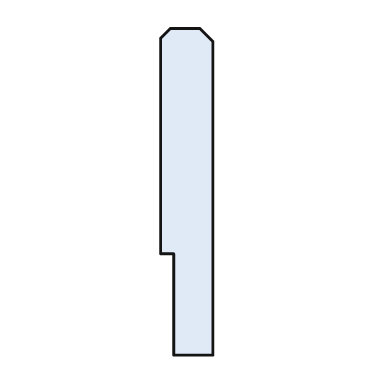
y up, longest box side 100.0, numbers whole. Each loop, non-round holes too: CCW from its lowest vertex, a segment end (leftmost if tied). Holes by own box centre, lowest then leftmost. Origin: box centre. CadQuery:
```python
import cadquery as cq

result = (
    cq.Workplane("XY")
    .moveTo(-4.0, -50.0)
    .lineTo(8.0, -50.0)
    .lineTo(8.0, 46.0)
    .lineTo(4.0, 50.0)
    .lineTo(-5.0, 50.0)
    .lineTo(-8.0, 47.0)
    .lineTo(-8.0, -19.0)
    .lineTo(-4.0, -19.0)
    .close()
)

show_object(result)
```